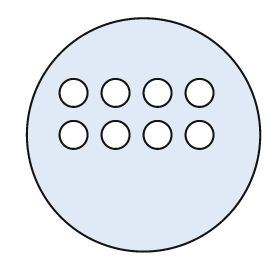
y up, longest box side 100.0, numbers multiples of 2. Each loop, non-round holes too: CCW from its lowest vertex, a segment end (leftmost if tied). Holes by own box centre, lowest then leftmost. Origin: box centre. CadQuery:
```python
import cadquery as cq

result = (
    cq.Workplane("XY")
    .moveTo(0.0, 0.0)
    .circle(50.0)
    .moveTo(-30.0, 0.0)
    .circle(6.0)
    .moveTo(-12.0, 0.0)
    .circle(6.0)
    .moveTo(6.0, 0.0)
    .circle(6.0)
    .moveTo(24.0, 0.0)
    .circle(6.0)
    .moveTo(-30.0, 18.0)
    .circle(6.0)
    .moveTo(-12.0, 18.0)
    .circle(6.0)
    .moveTo(6.0, 18.0)
    .circle(6.0)
    .moveTo(24.0, 18.0)
    .circle(6.0)
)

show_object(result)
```